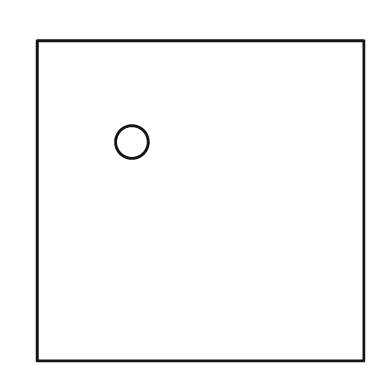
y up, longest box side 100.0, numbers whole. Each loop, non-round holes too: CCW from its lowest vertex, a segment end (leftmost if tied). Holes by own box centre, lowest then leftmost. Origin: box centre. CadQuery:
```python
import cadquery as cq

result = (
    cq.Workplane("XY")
    .moveTo(-50.0, -49.0)
    .lineTo(50.0, -49.0)
    .lineTo(50.0, 49.0)
    .lineTo(-50.0, 49.0)
    .close()
    .moveTo(-21.0, 18.0)
    .circle(5.0)
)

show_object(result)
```